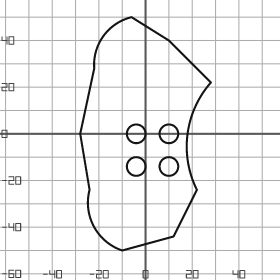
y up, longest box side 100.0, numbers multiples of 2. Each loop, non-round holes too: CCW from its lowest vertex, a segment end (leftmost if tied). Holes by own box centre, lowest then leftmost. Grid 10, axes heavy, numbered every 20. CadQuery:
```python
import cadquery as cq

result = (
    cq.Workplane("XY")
    .moveTo(-10.0, -50.0)
    .lineTo(12.0, -44.0)
    .lineTo(22.0, -24.0)
    .threePointArc((18.0, 0.0), (28.0, 22.0))
    .lineTo(10.0, 40.0)
    .lineTo(-6.0, 50.0)
    .threePointArc((-18.0, 42.0), (-22.0, 28.0))
    .lineTo(-28.0, 0.0)
    .lineTo(-24.0, -24.0)
    .threePointArc((-22.0, -40.0), (-10.0, -50.0))
    .close()
    .moveTo(-4.0, -14.0)
    .circle(4.0)
    .moveTo(10.0, -14.0)
    .circle(4.0)
    .moveTo(-4.0, 0.0)
    .circle(4.0)
    .moveTo(10.0, 0.0)
    .circle(4.0)
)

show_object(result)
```